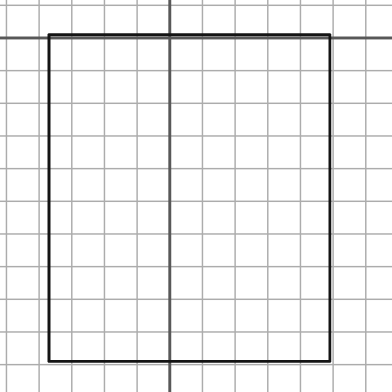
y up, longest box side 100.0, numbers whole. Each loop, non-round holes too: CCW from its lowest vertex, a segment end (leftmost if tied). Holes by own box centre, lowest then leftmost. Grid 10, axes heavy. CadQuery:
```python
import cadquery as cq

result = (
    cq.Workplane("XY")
    .moveTo(-37.0, -99.0)
    .lineTo(49.0, -99.0)
    .lineTo(49.0, 1.0)
    .lineTo(-37.0, 1.0)
    .close()
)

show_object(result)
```